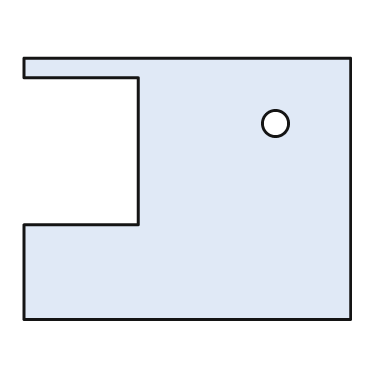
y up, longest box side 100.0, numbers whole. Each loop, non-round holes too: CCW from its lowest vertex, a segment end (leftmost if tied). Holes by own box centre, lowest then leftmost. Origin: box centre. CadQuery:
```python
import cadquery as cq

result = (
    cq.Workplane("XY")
    .moveTo(-50.0, -40.0)
    .lineTo(50.0, -40.0)
    .lineTo(50.0, 40.0)
    .lineTo(-50.0, 40.0)
    .lineTo(-50.0, 34.0)
    .lineTo(-15.0, 34.0)
    .lineTo(-15.0, -11.0)
    .lineTo(-50.0, -11.0)
    .close()
    .moveTo(27.0, 20.0)
    .circle(4.0)
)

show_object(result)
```